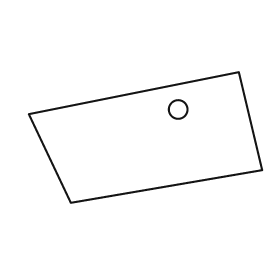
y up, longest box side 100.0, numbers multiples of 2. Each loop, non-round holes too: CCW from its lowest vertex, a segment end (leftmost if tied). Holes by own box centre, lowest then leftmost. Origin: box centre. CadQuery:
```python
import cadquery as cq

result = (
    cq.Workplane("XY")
    .moveTo(-32.0, -28.0)
    .lineTo(50.0, -14.0)
    .lineTo(40.0, 28.0)
    .lineTo(-50.0, 10.0)
    .close()
    .moveTo(14.0, 12.0)
    .circle(4.0)
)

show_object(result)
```